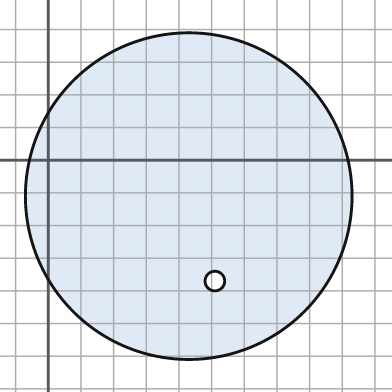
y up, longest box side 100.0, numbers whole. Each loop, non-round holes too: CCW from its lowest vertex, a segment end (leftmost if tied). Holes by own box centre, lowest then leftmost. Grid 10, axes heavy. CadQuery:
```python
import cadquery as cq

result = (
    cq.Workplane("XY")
    .moveTo(43.0, -11.0)
    .circle(50.0)
    .moveTo(51.0, -37.0)
    .circle(3.0)
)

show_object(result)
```